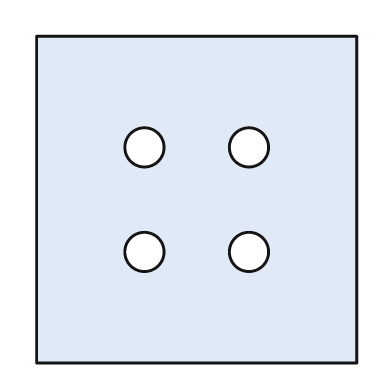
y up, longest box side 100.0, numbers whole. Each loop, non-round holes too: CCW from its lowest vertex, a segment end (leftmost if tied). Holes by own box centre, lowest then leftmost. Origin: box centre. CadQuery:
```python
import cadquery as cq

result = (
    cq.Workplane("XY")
    .moveTo(-49.0, -50.0)
    .lineTo(49.0, -50.0)
    .lineTo(49.0, 50.0)
    .lineTo(-49.0, 50.0)
    .close()
    .moveTo(-16.0, -16.0)
    .circle(6.0)
    .moveTo(16.0, -16.0)
    .circle(6.0)
    .moveTo(-16.0, 16.0)
    .circle(6.0)
    .moveTo(16.0, 16.0)
    .circle(6.0)
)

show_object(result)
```